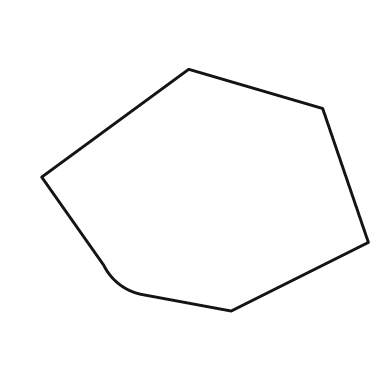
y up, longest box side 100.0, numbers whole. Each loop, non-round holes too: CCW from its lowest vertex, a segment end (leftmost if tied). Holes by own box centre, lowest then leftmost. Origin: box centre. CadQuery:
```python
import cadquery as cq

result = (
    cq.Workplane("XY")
    .moveTo(8.0, -37.0)
    .lineTo(50.0, -16.0)
    .lineTo(36.0, 25.0)
    .lineTo(-5.0, 37.0)
    .lineTo(-50.0, 4.0)
    .lineTo(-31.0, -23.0)
    .threePointArc((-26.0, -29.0), (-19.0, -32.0))
    .close()
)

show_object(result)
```